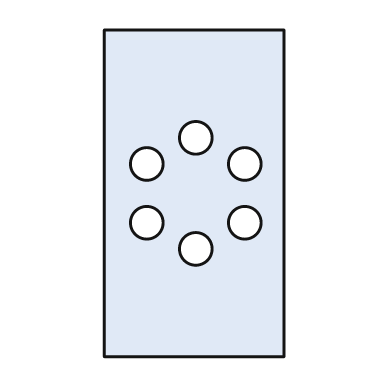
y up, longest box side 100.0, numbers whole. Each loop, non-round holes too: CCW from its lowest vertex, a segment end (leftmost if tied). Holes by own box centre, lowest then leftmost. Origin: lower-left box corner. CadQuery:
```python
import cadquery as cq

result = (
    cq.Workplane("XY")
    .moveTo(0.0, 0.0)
    .lineTo(55.0, 0.0)
    .lineTo(55.0, 100.0)
    .lineTo(0.0, 100.0)
    .close()
    .moveTo(28.0, 33.0)
    .circle(5.0)
    .moveTo(13.0, 41.0)
    .circle(5.0)
    .moveTo(43.0, 41.0)
    .circle(5.0)
    .moveTo(13.0, 59.0)
    .circle(5.0)
    .moveTo(43.0, 59.0)
    .circle(5.0)
    .moveTo(28.0, 67.0)
    .circle(5.0)
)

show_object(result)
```